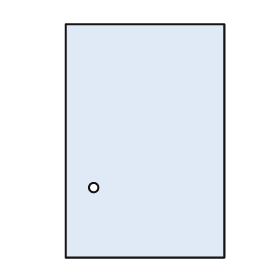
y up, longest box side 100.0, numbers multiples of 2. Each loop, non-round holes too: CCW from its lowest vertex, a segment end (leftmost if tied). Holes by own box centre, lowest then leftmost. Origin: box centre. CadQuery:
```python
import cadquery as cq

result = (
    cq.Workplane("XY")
    .moveTo(-34.0, -50.0)
    .lineTo(34.0, -50.0)
    .lineTo(34.0, 50.0)
    .lineTo(-34.0, 50.0)
    .close()
    .moveTo(-22.0, -20.0)
    .circle(2.0)
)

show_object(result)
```